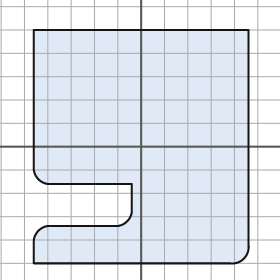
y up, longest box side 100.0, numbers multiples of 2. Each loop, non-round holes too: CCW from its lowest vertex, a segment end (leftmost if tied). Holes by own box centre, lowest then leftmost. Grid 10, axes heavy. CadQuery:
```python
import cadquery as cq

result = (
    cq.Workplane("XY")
    .moveTo(-46.0, -50.0)
    .lineTo(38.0, -50.0)
    .threePointArc((44.0, -48.0), (46.0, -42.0))
    .lineTo(46.0, 50.0)
    .lineTo(-46.0, 50.0)
    .lineTo(-46.0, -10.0)
    .threePointArc((-44.0, -14.0), (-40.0, -16.0))
    .lineTo(-4.0, -16.0)
    .lineTo(-4.0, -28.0)
    .threePointArc((-6.0, -32.0), (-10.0, -34.0))
    .lineTo(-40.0, -34.0)
    .threePointArc((-44.0, -36.0), (-46.0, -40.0))
    .close()
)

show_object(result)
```